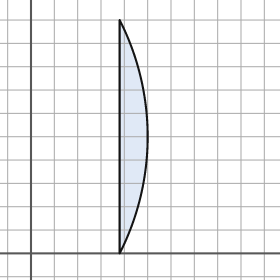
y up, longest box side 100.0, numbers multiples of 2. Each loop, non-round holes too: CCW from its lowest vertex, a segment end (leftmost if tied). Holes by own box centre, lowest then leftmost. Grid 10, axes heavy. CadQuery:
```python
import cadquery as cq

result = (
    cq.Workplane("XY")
    .moveTo(38.0, 0.0)
    .threePointArc((50.0, 50.0), (38.0, 100.0))
    .close()
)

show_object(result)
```